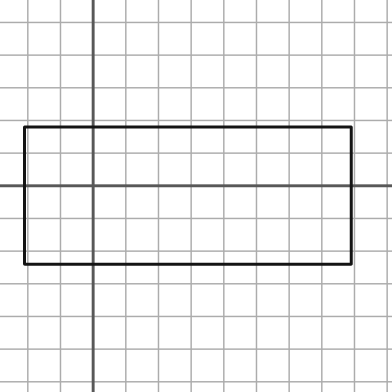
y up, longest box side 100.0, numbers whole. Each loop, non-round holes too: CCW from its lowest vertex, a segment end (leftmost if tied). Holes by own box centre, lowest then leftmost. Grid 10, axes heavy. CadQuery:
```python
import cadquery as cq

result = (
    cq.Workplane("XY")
    .moveTo(-21.0, -24.0)
    .lineTo(79.0, -24.0)
    .lineTo(79.0, 18.0)
    .lineTo(-21.0, 18.0)
    .close()
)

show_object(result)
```